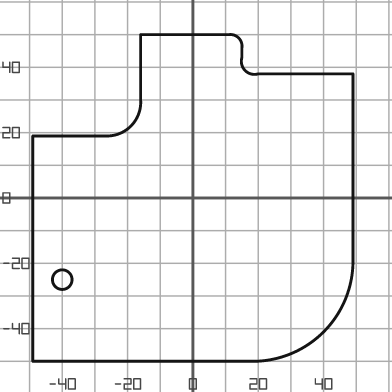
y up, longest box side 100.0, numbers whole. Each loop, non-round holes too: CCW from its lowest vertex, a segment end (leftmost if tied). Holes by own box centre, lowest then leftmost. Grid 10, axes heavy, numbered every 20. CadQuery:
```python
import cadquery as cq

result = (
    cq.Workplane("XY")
    .moveTo(-49.0, -50.0)
    .lineTo(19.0, -50.0)
    .threePointArc((40.0, -41.0), (49.0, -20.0))
    .lineTo(49.0, 38.0)
    .lineTo(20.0, 38.0)
    .threePointArc((16.0, 39.0), (15.0, 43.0))
    .lineTo(15.0, 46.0)
    .threePointArc((14.0, 49.0), (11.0, 50.0))
    .lineTo(-16.0, 50.0)
    .lineTo(-16.0, 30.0)
    .threePointArc((-19.0, 22.0), (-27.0, 19.0))
    .lineTo(-49.0, 19.0)
    .close()
    .moveTo(-40.0, -25.0)
    .circle(3.0)
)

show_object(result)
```